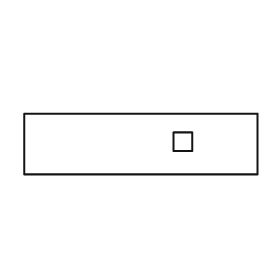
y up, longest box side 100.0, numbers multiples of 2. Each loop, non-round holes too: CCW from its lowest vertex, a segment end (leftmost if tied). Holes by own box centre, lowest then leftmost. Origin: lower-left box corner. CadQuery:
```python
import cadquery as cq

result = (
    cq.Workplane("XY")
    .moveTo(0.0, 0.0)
    .lineTo(100.0, 0.0)
    .lineTo(100.0, 26.0)
    .lineTo(0.0, 26.0)
    .close()
    .moveTo(64.0, 10.0)
    .lineTo(72.0, 10.0)
    .lineTo(72.0, 18.0)
    .lineTo(64.0, 18.0)
    .close()
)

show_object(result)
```